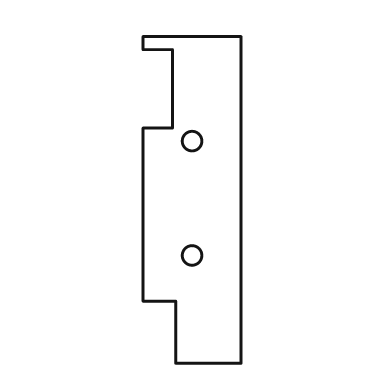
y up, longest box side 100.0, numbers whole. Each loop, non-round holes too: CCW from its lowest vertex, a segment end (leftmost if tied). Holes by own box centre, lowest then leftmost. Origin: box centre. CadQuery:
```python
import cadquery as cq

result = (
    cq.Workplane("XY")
    .moveTo(-5.0, -50.0)
    .lineTo(15.0, -50.0)
    .lineTo(15.0, 50.0)
    .lineTo(-15.0, 50.0)
    .lineTo(-15.0, 46.0)
    .lineTo(-6.0, 46.0)
    .lineTo(-6.0, 22.0)
    .lineTo(-15.0, 22.0)
    .lineTo(-15.0, -31.0)
    .lineTo(-5.0, -31.0)
    .close()
    .moveTo(0.0, -17.0)
    .circle(3.0)
    .moveTo(0.0, 18.0)
    .circle(3.0)
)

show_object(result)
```